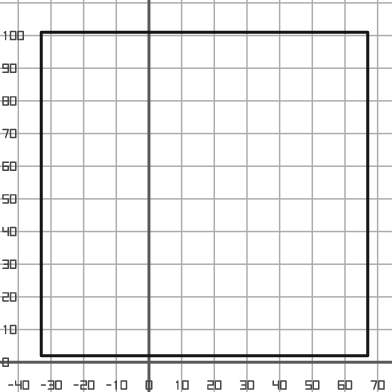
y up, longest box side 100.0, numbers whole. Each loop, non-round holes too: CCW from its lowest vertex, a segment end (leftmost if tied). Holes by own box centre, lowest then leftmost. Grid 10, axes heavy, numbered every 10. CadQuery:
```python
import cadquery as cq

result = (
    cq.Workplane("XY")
    .moveTo(-33.0, 2.0)
    .lineTo(67.0, 2.0)
    .lineTo(67.0, 101.0)
    .lineTo(-33.0, 101.0)
    .close()
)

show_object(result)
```